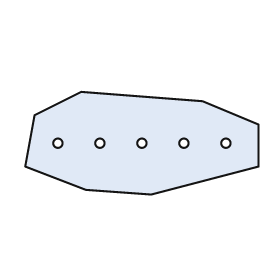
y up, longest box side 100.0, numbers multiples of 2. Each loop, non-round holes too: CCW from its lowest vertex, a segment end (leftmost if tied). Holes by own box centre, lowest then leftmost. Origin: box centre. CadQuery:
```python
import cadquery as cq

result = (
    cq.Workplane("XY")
    .moveTo(4.0, -22.0)
    .lineTo(50.0, -10.0)
    .lineTo(50.0, 8.0)
    .lineTo(26.0, 18.0)
    .lineTo(-26.0, 22.0)
    .lineTo(-46.0, 12.0)
    .lineTo(-50.0, -10.0)
    .lineTo(-24.0, -20.0)
    .close()
    .moveTo(-36.0, 0.0)
    .circle(2.0)
    .moveTo(-18.0, 0.0)
    .circle(2.0)
    .moveTo(0.0, 0.0)
    .circle(2.0)
    .moveTo(18.0, 0.0)
    .circle(2.0)
    .moveTo(36.0, 0.0)
    .circle(2.0)
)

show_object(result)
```